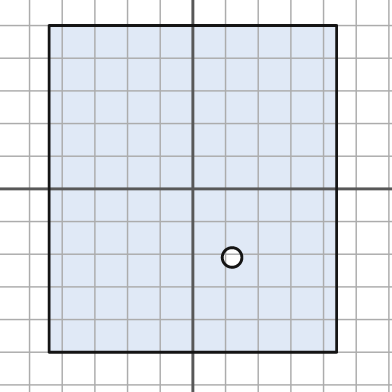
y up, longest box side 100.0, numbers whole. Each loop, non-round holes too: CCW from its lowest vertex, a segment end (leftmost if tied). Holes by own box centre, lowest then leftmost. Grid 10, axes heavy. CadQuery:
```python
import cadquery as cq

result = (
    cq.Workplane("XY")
    .moveTo(-44.0, -50.0)
    .lineTo(44.0, -50.0)
    .lineTo(44.0, 50.0)
    .lineTo(-44.0, 50.0)
    .close()
    .moveTo(12.0, -21.0)
    .circle(3.0)
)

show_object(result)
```